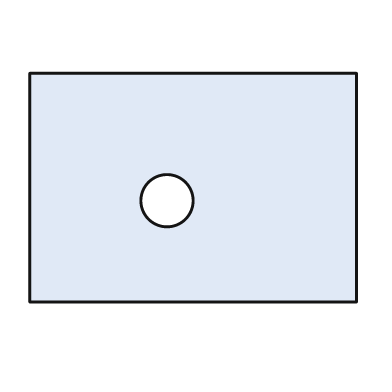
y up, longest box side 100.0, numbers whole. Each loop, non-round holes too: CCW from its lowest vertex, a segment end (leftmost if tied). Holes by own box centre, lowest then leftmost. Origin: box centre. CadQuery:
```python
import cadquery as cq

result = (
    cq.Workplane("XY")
    .moveTo(-50.0, -35.0)
    .lineTo(50.0, -35.0)
    .lineTo(50.0, 35.0)
    .lineTo(-50.0, 35.0)
    .close()
    .moveTo(-8.0, -4.0)
    .circle(8.0)
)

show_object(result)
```